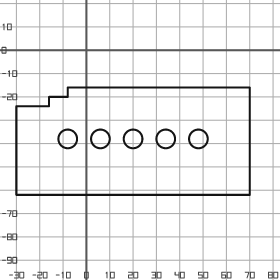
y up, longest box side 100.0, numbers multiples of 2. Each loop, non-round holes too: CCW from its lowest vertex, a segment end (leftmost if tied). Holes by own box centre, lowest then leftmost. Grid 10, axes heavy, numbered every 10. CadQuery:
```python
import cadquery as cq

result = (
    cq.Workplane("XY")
    .moveTo(-30.0, -62.0)
    .lineTo(70.0, -62.0)
    .lineTo(70.0, -16.0)
    .lineTo(-8.0, -16.0)
    .lineTo(-8.0, -20.0)
    .lineTo(-16.0, -20.0)
    .lineTo(-16.0, -24.0)
    .lineTo(-30.0, -24.0)
    .close()
    .moveTo(-8.0, -38.0)
    .circle(4.0)
    .moveTo(6.0, -38.0)
    .circle(4.0)
    .moveTo(20.0, -38.0)
    .circle(4.0)
    .moveTo(34.0, -38.0)
    .circle(4.0)
    .moveTo(48.0, -38.0)
    .circle(4.0)
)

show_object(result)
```